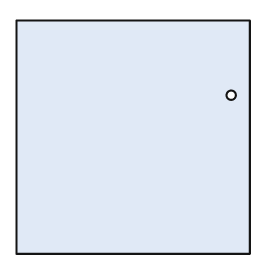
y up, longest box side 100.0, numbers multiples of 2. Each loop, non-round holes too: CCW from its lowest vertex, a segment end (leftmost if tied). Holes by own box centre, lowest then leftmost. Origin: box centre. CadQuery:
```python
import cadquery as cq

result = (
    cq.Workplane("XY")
    .moveTo(-50.0, -50.0)
    .lineTo(50.0, -50.0)
    .lineTo(50.0, 50.0)
    .lineTo(-50.0, 50.0)
    .close()
    .moveTo(42.0, 18.0)
    .circle(2.0)
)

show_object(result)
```